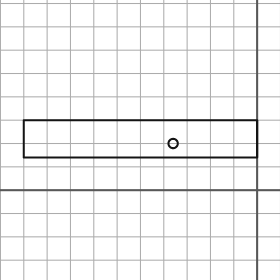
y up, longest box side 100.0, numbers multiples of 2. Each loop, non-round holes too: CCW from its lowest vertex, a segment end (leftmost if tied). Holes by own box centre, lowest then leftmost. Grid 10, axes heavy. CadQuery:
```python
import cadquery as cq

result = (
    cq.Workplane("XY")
    .moveTo(-100.0, 14.0)
    .lineTo(0.0, 14.0)
    .lineTo(0.0, 30.0)
    .lineTo(-100.0, 30.0)
    .close()
    .moveTo(-36.0, 20.0)
    .circle(2.0)
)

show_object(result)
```